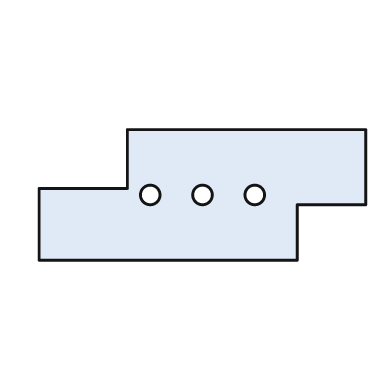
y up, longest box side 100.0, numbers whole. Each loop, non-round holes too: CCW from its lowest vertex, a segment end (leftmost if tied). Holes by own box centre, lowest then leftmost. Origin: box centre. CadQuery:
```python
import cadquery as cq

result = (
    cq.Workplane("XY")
    .moveTo(-50.0, -20.0)
    .lineTo(29.0, -20.0)
    .lineTo(29.0, -3.0)
    .lineTo(50.0, -3.0)
    .lineTo(50.0, 20.0)
    .lineTo(-23.0, 20.0)
    .lineTo(-23.0, 2.0)
    .lineTo(-50.0, 2.0)
    .close()
    .moveTo(-16.0, 0.0)
    .circle(3.0)
    .moveTo(0.0, 0.0)
    .circle(3.0)
    .moveTo(16.0, 0.0)
    .circle(3.0)
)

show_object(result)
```